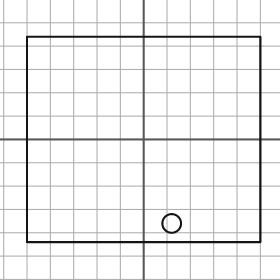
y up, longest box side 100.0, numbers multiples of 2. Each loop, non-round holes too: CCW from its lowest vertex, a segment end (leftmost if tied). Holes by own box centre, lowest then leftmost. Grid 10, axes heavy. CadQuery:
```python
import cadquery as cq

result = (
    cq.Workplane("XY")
    .moveTo(-50.0, -44.0)
    .lineTo(50.0, -44.0)
    .lineTo(50.0, 44.0)
    .lineTo(-50.0, 44.0)
    .close()
    .moveTo(12.0, -36.0)
    .circle(4.0)
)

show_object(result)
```